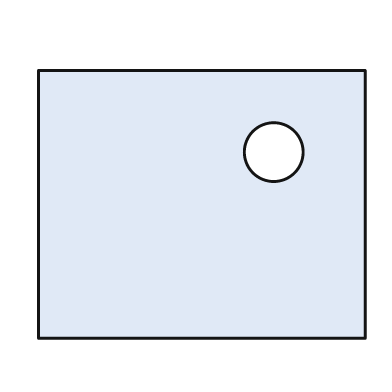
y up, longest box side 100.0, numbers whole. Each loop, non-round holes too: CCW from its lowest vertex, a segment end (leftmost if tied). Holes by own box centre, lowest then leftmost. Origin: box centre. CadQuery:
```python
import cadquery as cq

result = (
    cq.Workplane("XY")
    .moveTo(-50.0, -41.0)
    .lineTo(50.0, -41.0)
    .lineTo(50.0, 41.0)
    .lineTo(-50.0, 41.0)
    .close()
    .moveTo(22.0, 16.0)
    .circle(9.0)
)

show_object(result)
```